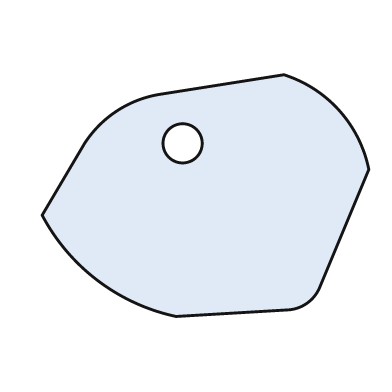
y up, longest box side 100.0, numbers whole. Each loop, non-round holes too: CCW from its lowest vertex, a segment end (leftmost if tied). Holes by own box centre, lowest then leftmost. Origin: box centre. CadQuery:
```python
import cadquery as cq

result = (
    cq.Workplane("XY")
    .moveTo(-9.0, -37.0)
    .lineTo(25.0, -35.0)
    .threePointArc((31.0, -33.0), (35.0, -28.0))
    .lineTo(50.0, 8.0)
    .threePointArc((41.0, 26.0), (24.0, 37.0))
    .lineTo(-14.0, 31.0)
    .threePointArc((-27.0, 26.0), (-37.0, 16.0))
    .lineTo(-50.0, -6.0)
    .threePointArc((-33.0, -26.0), (-9.0, -37.0))
    .close()
    .moveTo(-7.0, 16.0)
    .circle(6.0)
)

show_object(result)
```